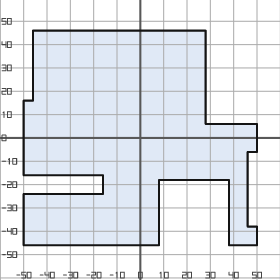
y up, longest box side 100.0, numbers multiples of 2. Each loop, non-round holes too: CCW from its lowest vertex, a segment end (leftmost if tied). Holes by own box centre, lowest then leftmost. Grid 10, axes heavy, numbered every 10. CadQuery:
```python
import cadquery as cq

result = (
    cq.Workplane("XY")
    .moveTo(-50.0, -46.0)
    .lineTo(8.0, -46.0)
    .lineTo(8.0, -18.0)
    .lineTo(38.0, -18.0)
    .lineTo(38.0, -46.0)
    .lineTo(50.0, -46.0)
    .lineTo(50.0, -38.0)
    .lineTo(46.0, -38.0)
    .lineTo(46.0, -6.0)
    .lineTo(50.0, -6.0)
    .lineTo(50.0, 6.0)
    .lineTo(28.0, 6.0)
    .lineTo(28.0, 46.0)
    .lineTo(-46.0, 46.0)
    .lineTo(-46.0, 16.0)
    .lineTo(-50.0, 16.0)
    .lineTo(-50.0, -16.0)
    .lineTo(-16.0, -16.0)
    .lineTo(-16.0, -24.0)
    .lineTo(-50.0, -24.0)
    .close()
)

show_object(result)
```